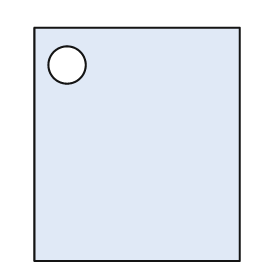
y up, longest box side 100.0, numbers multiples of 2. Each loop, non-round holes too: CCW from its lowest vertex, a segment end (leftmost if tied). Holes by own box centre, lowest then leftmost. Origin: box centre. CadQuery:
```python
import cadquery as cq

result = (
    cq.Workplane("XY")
    .moveTo(-44.0, -50.0)
    .lineTo(44.0, -50.0)
    .lineTo(44.0, 50.0)
    .lineTo(-44.0, 50.0)
    .close()
    .moveTo(-30.0, 34.0)
    .circle(8.0)
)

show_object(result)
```